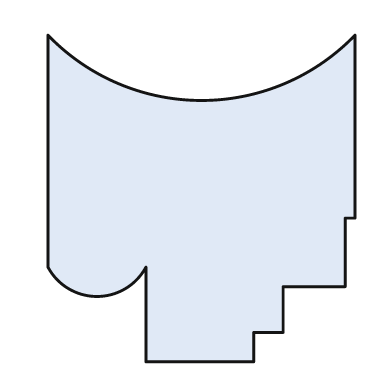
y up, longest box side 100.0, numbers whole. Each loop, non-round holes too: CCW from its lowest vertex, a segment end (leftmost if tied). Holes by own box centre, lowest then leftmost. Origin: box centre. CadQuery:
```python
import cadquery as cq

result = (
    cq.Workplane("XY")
    .moveTo(-17.0, -50.0)
    .lineTo(16.0, -50.0)
    .lineTo(16.0, -41.0)
    .lineTo(25.0, -41.0)
    .lineTo(25.0, -27.0)
    .lineTo(44.0, -27.0)
    .lineTo(44.0, -6.0)
    .lineTo(47.0, -6.0)
    .lineTo(47.0, 50.0)
    .threePointArc((0.0, 30.0), (-47.0, 50.0))
    .lineTo(-47.0, -21.0)
    .threePointArc((-32.0, -30.0), (-17.0, -21.0))
    .close()
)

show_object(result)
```